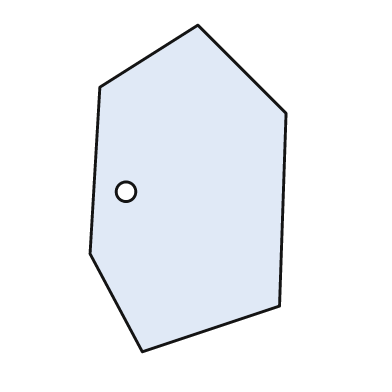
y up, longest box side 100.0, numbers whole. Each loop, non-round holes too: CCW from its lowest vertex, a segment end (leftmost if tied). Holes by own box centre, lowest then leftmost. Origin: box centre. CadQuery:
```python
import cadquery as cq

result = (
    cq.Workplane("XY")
    .moveTo(-14.0, -50.0)
    .lineTo(28.0, -36.0)
    .lineTo(30.0, 23.0)
    .lineTo(3.0, 50.0)
    .lineTo(-27.0, 31.0)
    .lineTo(-30.0, -20.0)
    .close()
    .moveTo(-19.0, -1.0)
    .circle(3.0)
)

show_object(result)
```